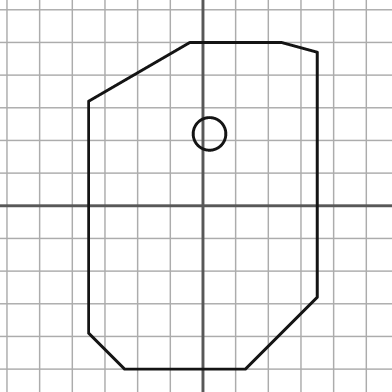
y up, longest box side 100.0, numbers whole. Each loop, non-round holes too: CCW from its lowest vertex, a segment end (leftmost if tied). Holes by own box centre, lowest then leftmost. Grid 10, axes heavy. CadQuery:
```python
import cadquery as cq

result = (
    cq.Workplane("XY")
    .moveTo(-24.0, -50.0)
    .lineTo(13.0, -50.0)
    .lineTo(35.0, -28.0)
    .lineTo(35.0, 47.0)
    .lineTo(24.0, 50.0)
    .lineTo(-4.0, 50.0)
    .lineTo(-35.0, 32.0)
    .lineTo(-35.0, -39.0)
    .close()
    .moveTo(2.0, 22.0)
    .circle(5.0)
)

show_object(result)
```